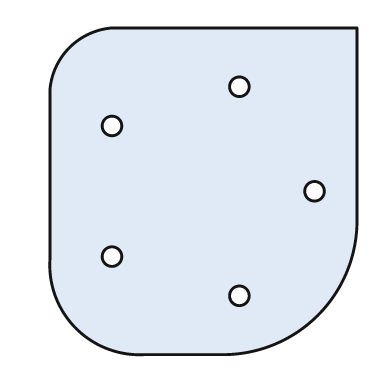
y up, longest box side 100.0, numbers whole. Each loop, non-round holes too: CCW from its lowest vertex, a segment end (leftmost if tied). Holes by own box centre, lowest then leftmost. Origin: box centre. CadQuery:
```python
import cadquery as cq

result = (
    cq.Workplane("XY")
    .moveTo(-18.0, -50.0)
    .lineTo(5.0, -50.0)
    .threePointArc((35.0, -38.0), (47.0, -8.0))
    .lineTo(47.0, 50.0)
    .lineTo(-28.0, 50.0)
    .threePointArc((-41.0, 44.0), (-47.0, 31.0))
    .lineTo(-47.0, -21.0)
    .threePointArc((-39.0, -42.0), (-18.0, -50.0))
    .close()
    .moveTo(11.0, -32.0)
    .circle(3.0)
    .moveTo(-28.0, -20.0)
    .circle(3.0)
    .moveTo(34.0, 0.0)
    .circle(3.0)
    .moveTo(-28.0, 20.0)
    .circle(3.0)
    .moveTo(11.0, 32.0)
    .circle(3.0)
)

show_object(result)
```